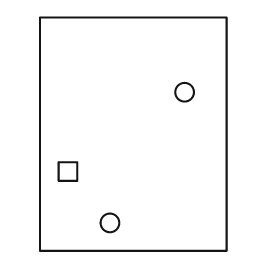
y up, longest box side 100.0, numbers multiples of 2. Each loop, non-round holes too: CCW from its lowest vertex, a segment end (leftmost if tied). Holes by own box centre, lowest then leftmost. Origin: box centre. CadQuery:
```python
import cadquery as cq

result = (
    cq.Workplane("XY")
    .moveTo(-40.0, -50.0)
    .lineTo(40.0, -50.0)
    .lineTo(40.0, 50.0)
    .lineTo(-40.0, 50.0)
    .close()
    .moveTo(-10.0, -38.0)
    .circle(4.0)
    .moveTo(-32.0, -20.0)
    .lineTo(-24.0, -20.0)
    .lineTo(-24.0, -12.0)
    .lineTo(-32.0, -12.0)
    .close()
    .moveTo(22.0, 18.0)
    .circle(4.0)
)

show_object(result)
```